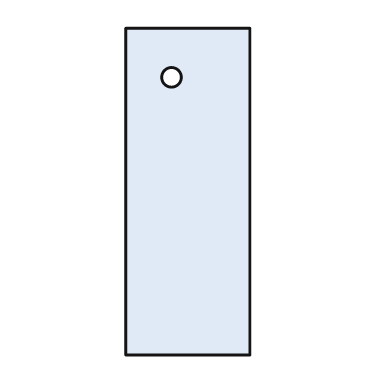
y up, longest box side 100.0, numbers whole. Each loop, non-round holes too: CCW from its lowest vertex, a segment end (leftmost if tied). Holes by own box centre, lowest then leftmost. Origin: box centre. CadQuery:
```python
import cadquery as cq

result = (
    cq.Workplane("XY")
    .moveTo(-19.0, -50.0)
    .lineTo(19.0, -50.0)
    .lineTo(19.0, 50.0)
    .lineTo(-19.0, 50.0)
    .close()
    .moveTo(-5.0, 35.0)
    .circle(3.0)
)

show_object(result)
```